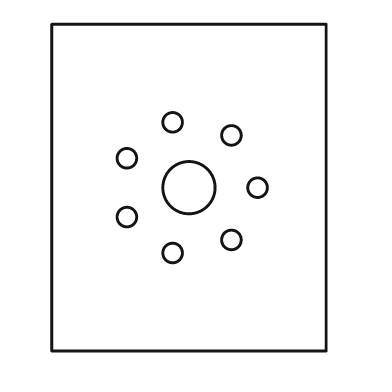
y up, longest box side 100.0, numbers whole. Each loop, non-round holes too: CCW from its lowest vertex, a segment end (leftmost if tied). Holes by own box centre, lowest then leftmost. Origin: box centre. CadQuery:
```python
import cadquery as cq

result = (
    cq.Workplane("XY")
    .moveTo(-42.0, -50.0)
    .lineTo(42.0, -50.0)
    .lineTo(42.0, 50.0)
    .lineTo(-42.0, 50.0)
    .close()
    .moveTo(-5.0, -20.0)
    .circle(3.0)
    .moveTo(13.0, -16.0)
    .circle(3.0)
    .moveTo(-19.0, -9.0)
    .circle(3.0)
    .moveTo(0.0, 0.0)
    .circle(8.0)
    .moveTo(21.0, 0.0)
    .circle(3.0)
    .moveTo(-19.0, 9.0)
    .circle(3.0)
    .moveTo(13.0, 16.0)
    .circle(3.0)
    .moveTo(-5.0, 20.0)
    .circle(3.0)
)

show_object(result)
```